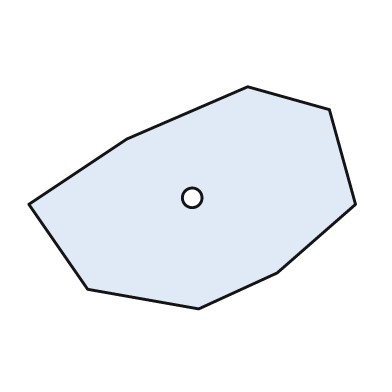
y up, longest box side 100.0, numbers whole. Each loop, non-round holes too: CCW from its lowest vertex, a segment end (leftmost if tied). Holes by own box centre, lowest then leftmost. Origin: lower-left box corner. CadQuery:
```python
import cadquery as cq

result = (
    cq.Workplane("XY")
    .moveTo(52.0, 0.0)
    .lineTo(76.0, 11.0)
    .lineTo(100.0, 32.0)
    .lineTo(92.0, 61.0)
    .lineTo(67.0, 68.0)
    .lineTo(30.0, 52.0)
    .lineTo(0.0, 32.0)
    .lineTo(18.0, 6.0)
    .close()
    .moveTo(50.0, 34.0)
    .circle(3.0)
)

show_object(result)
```